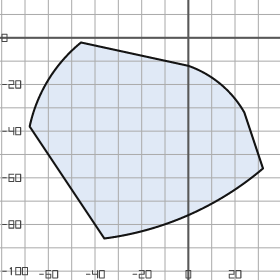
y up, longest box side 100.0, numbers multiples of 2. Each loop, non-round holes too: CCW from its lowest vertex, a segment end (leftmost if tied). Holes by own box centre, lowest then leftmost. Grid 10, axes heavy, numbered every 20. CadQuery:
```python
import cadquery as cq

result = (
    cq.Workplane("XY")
    .moveTo(-36.0, -86.0)
    .threePointArc((0.0, -76.0), (32.0, -56.0))
    .lineTo(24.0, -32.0)
    .threePointArc((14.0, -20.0), (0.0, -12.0))
    .lineTo(-46.0, -2.0)
    .threePointArc((-60.0, -18.0), (-68.0, -38.0))
    .close()
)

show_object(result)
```